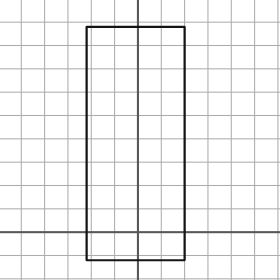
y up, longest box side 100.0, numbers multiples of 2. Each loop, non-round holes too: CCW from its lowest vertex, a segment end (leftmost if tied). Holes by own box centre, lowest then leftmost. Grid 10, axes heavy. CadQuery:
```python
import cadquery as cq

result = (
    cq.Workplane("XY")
    .moveTo(-22.0, -12.0)
    .lineTo(20.0, -12.0)
    .lineTo(20.0, 88.0)
    .lineTo(-22.0, 88.0)
    .close()
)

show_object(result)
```